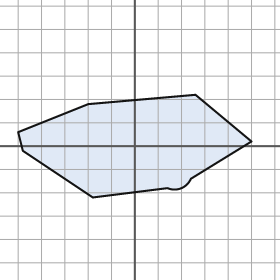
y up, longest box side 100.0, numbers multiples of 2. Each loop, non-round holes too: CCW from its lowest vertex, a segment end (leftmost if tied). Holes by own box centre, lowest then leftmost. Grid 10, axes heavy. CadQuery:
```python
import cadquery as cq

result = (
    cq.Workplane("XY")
    .moveTo(-18.0, -22.0)
    .lineTo(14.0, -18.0)
    .threePointArc((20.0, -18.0), (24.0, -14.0))
    .lineTo(50.0, 2.0)
    .lineTo(26.0, 22.0)
    .lineTo(-20.0, 18.0)
    .lineTo(-50.0, 6.0)
    .lineTo(-48.0, -2.0)
    .close()
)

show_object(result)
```